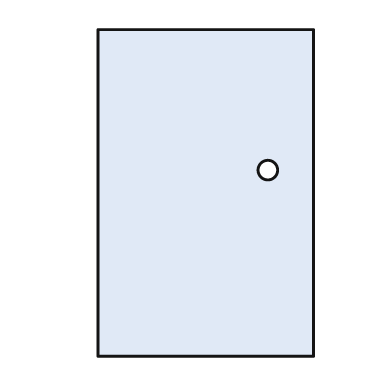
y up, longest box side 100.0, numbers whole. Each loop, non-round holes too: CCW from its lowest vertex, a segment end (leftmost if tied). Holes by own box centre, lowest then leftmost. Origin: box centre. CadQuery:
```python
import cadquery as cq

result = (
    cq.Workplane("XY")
    .moveTo(-33.0, -50.0)
    .lineTo(33.0, -50.0)
    .lineTo(33.0, 50.0)
    .lineTo(-33.0, 50.0)
    .close()
    .moveTo(19.0, 7.0)
    .circle(3.0)
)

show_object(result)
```